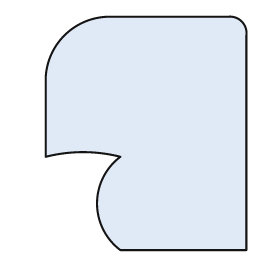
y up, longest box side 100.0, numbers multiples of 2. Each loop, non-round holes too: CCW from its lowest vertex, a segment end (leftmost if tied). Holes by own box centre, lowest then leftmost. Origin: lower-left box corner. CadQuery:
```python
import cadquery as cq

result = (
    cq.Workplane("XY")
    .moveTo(32.0, 0.0)
    .lineTo(86.0, 0.0)
    .lineTo(86.0, 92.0)
    .threePointArc((84.0, 98.0), (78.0, 100.0))
    .lineTo(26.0, 100.0)
    .threePointArc((8.0, 92.0), (0.0, 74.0))
    .lineTo(0.0, 40.0)
    .threePointArc((16.0, 42.0), (32.0, 40.0))
    .threePointArc((22.0, 20.0), (32.0, 0.0))
    .close()
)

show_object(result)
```